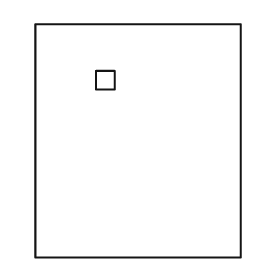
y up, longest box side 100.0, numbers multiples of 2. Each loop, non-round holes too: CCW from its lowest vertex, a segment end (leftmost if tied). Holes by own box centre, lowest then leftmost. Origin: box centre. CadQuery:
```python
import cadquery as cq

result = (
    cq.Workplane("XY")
    .moveTo(-44.0, -50.0)
    .lineTo(44.0, -50.0)
    .lineTo(44.0, 50.0)
    .lineTo(-44.0, 50.0)
    .close()
    .moveTo(-18.0, 22.0)
    .lineTo(-10.0, 22.0)
    .lineTo(-10.0, 30.0)
    .lineTo(-18.0, 30.0)
    .close()
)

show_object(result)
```